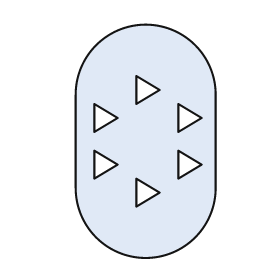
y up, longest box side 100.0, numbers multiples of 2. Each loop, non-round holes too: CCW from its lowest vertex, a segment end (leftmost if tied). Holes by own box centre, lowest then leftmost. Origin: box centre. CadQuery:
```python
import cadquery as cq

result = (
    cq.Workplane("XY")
    .moveTo(-30.0, -20.0)
    .threePointArc((0.0, -50.0), (30.0, -20.0))
    .lineTo(30.0, 20.0)
    .threePointArc((0.0, 50.0), (-30.0, 20.0))
    .close()
    .moveTo(-4.0, -28.0)
    .lineTo(6.0, -22.0)
    .lineTo(-4.0, -16.0)
    .close()
    .moveTo(-22.0, -16.0)
    .lineTo(-12.0, -10.0)
    .lineTo(-22.0, -4.0)
    .close()
    .moveTo(14.0, -16.0)
    .lineTo(24.0, -10.0)
    .lineTo(14.0, -4.0)
    .close()
    .moveTo(-22.0, 4.0)
    .lineTo(-12.0, 10.0)
    .lineTo(-22.0, 16.0)
    .close()
    .moveTo(14.0, 4.0)
    .lineTo(24.0, 10.0)
    .lineTo(14.0, 16.0)
    .close()
    .moveTo(-4.0, 16.0)
    .lineTo(6.0, 22.0)
    .lineTo(-4.0, 28.0)
    .close()
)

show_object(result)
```